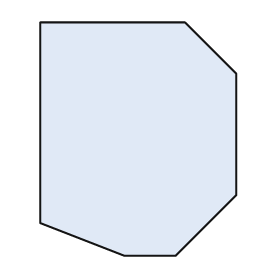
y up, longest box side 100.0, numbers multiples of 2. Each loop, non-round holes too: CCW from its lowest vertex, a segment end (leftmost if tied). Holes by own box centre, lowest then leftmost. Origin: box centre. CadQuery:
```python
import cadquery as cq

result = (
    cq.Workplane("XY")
    .moveTo(-6.0, -50.0)
    .lineTo(16.0, -50.0)
    .lineTo(42.0, -24.0)
    .lineTo(42.0, 28.0)
    .lineTo(20.0, 50.0)
    .lineTo(-42.0, 50.0)
    .lineTo(-42.0, -36.0)
    .close()
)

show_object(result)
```